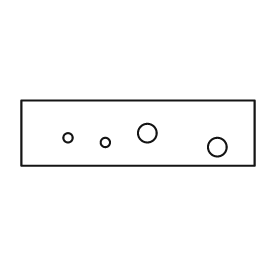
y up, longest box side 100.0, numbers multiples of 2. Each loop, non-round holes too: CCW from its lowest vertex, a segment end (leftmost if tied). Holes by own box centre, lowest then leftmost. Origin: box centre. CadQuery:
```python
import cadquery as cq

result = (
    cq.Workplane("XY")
    .moveTo(-50.0, -14.0)
    .lineTo(50.0, -14.0)
    .lineTo(50.0, 14.0)
    .lineTo(-50.0, 14.0)
    .close()
    .moveTo(34.0, -6.0)
    .circle(4.0)
    .moveTo(-14.0, -4.0)
    .circle(2.0)
    .moveTo(-30.0, -2.0)
    .circle(2.0)
    .moveTo(4.0, 0.0)
    .circle(4.0)
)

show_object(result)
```